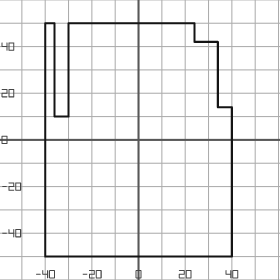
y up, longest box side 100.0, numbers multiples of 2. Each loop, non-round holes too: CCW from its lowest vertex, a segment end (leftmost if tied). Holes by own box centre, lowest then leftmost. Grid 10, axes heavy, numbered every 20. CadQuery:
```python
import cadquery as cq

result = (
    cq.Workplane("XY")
    .moveTo(-40.0, -50.0)
    .lineTo(40.0, -50.0)
    .lineTo(40.0, 14.0)
    .lineTo(34.0, 14.0)
    .lineTo(34.0, 42.0)
    .lineTo(24.0, 42.0)
    .lineTo(24.0, 50.0)
    .lineTo(-30.0, 50.0)
    .lineTo(-30.0, 10.0)
    .lineTo(-36.0, 10.0)
    .lineTo(-36.0, 50.0)
    .lineTo(-40.0, 50.0)
    .close()
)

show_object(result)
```